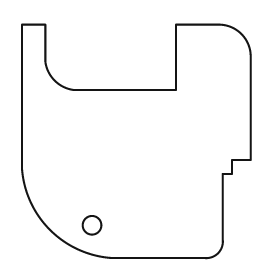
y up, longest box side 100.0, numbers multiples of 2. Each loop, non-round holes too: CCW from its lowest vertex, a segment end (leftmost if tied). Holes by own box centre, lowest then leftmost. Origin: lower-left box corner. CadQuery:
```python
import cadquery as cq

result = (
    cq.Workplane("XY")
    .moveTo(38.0, 0.0)
    .lineTo(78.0, 0.0)
    .threePointArc((84.0, 2.0), (86.0, 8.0))
    .lineTo(86.0, 36.0)
    .lineTo(90.0, 36.0)
    .lineTo(90.0, 42.0)
    .lineTo(98.0, 42.0)
    .lineTo(98.0, 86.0)
    .threePointArc((94.0, 96.0), (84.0, 100.0))
    .lineTo(66.0, 100.0)
    .lineTo(66.0, 72.0)
    .lineTo(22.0, 72.0)
    .threePointArc((14.0, 76.0), (10.0, 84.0))
    .lineTo(10.0, 100.0)
    .lineTo(0.0, 100.0)
    .lineTo(0.0, 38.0)
    .threePointArc((12.0, 12.0), (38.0, 0.0))
    .close()
    .moveTo(30.0, 14.0)
    .circle(4.0)
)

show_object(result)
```